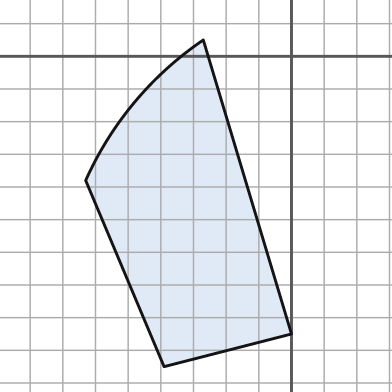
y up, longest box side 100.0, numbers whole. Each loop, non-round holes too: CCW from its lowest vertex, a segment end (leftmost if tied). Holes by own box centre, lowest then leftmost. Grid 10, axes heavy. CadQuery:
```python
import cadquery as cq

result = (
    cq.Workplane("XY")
    .moveTo(-39.0, -95.0)
    .lineTo(0.0, -85.0)
    .lineTo(-27.0, 5.0)
    .threePointArc((-48.0, -14.0), (-63.0, -38.0))
    .close()
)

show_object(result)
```